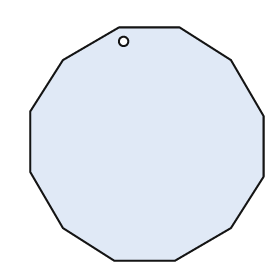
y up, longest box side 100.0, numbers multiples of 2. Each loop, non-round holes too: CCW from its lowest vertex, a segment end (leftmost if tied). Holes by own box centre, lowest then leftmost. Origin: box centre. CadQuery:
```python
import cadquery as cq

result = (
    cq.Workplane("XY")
    .moveTo(-14.0, -50.0)
    .lineTo(12.0, -50.0)
    .lineTo(36.0, -36.0)
    .lineTo(50.0, -14.0)
    .lineTo(50.0, 12.0)
    .lineTo(36.0, 36.0)
    .lineTo(14.0, 50.0)
    .lineTo(-12.0, 50.0)
    .lineTo(-36.0, 36.0)
    .lineTo(-50.0, 14.0)
    .lineTo(-50.0, -12.0)
    .lineTo(-36.0, -36.0)
    .close()
    .moveTo(-10.0, 44.0)
    .circle(2.0)
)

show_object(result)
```